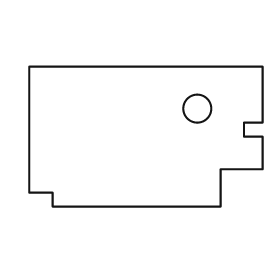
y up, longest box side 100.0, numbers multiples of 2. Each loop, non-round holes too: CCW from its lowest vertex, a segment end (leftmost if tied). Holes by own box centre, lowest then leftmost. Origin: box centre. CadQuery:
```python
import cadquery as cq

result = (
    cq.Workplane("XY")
    .moveTo(-40.0, -30.0)
    .lineTo(32.0, -30.0)
    .lineTo(32.0, -14.0)
    .lineTo(50.0, -14.0)
    .lineTo(50.0, 0.0)
    .lineTo(42.0, 0.0)
    .lineTo(42.0, 6.0)
    .lineTo(50.0, 6.0)
    .lineTo(50.0, 30.0)
    .lineTo(-50.0, 30.0)
    .lineTo(-50.0, -24.0)
    .lineTo(-40.0, -24.0)
    .close()
    .moveTo(22.0, 12.0)
    .circle(6.0)
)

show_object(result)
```